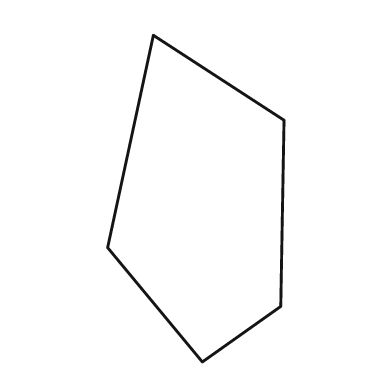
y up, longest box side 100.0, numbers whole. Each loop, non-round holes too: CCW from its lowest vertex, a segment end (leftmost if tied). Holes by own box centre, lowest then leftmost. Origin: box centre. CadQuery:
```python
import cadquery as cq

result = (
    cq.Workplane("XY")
    .moveTo(2.0, -50.0)
    .lineTo(26.0, -33.0)
    .lineTo(27.0, 24.0)
    .lineTo(-13.0, 50.0)
    .lineTo(-27.0, -15.0)
    .close()
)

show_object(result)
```